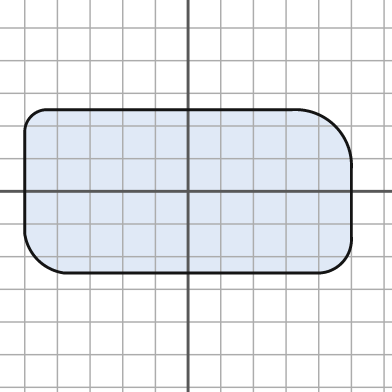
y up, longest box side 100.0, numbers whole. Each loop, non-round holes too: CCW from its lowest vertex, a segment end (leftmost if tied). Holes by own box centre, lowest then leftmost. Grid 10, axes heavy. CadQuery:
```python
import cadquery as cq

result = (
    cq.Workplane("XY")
    .moveTo(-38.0, -25.0)
    .lineTo(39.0, -25.0)
    .threePointArc((47.0, -22.0), (50.0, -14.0))
    .lineTo(50.0, 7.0)
    .threePointArc((45.0, 20.0), (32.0, 25.0))
    .lineTo(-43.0, 25.0)
    .threePointArc((-48.0, 23.0), (-50.0, 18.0))
    .lineTo(-50.0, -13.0)
    .threePointArc((-46.0, -21.0), (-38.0, -25.0))
    .close()
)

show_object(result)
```